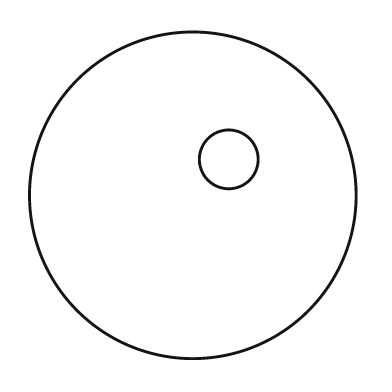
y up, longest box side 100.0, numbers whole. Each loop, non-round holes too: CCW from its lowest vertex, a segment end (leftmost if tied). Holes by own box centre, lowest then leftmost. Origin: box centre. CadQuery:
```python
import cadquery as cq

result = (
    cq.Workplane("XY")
    .moveTo(0.0, 0.0)
    .circle(50.0)
    .moveTo(11.0, 11.0)
    .circle(9.0)
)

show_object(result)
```